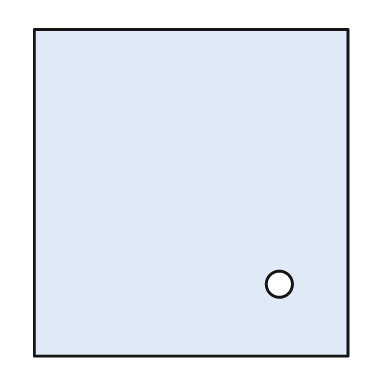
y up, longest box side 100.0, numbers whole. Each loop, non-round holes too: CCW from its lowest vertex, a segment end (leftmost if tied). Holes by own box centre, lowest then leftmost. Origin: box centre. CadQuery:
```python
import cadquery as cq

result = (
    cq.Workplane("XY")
    .moveTo(-48.0, -50.0)
    .lineTo(48.0, -50.0)
    .lineTo(48.0, 50.0)
    .lineTo(-48.0, 50.0)
    .close()
    .moveTo(27.0, -28.0)
    .circle(4.0)
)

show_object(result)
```